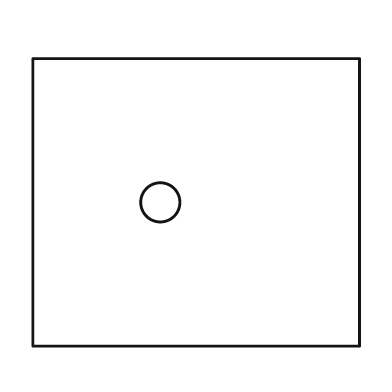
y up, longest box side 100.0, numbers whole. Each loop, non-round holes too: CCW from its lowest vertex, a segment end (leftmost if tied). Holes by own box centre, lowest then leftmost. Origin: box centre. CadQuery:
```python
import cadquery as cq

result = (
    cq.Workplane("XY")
    .moveTo(-50.0, -44.0)
    .lineTo(50.0, -44.0)
    .lineTo(50.0, 44.0)
    .lineTo(-50.0, 44.0)
    .close()
    .moveTo(-11.0, 0.0)
    .circle(6.0)
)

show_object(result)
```